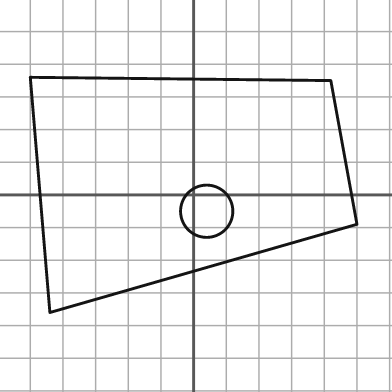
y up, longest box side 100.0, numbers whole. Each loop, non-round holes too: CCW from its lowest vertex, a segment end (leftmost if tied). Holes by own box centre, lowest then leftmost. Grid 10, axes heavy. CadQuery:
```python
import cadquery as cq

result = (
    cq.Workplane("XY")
    .moveTo(-44.0, -36.0)
    .lineTo(50.0, -9.0)
    .lineTo(42.0, 35.0)
    .lineTo(-50.0, 36.0)
    .close()
    .moveTo(4.0, -5.0)
    .circle(8.0)
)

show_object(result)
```